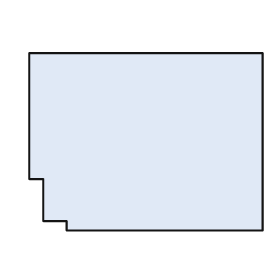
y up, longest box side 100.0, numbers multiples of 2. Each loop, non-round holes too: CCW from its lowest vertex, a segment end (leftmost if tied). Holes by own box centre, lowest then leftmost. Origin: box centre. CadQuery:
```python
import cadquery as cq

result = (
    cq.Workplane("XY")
    .moveTo(-34.0, -38.0)
    .lineTo(50.0, -38.0)
    .lineTo(50.0, 38.0)
    .lineTo(-50.0, 38.0)
    .lineTo(-50.0, -16.0)
    .lineTo(-44.0, -16.0)
    .lineTo(-44.0, -34.0)
    .lineTo(-34.0, -34.0)
    .close()
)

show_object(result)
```